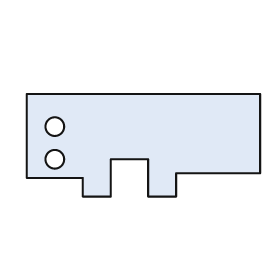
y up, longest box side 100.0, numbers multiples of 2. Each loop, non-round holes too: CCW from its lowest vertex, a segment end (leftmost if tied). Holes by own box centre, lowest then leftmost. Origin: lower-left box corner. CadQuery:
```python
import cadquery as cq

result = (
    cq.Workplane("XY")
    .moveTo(24.0, 0.0)
    .lineTo(36.0, 0.0)
    .lineTo(36.0, 16.0)
    .lineTo(52.0, 16.0)
    .lineTo(52.0, 0.0)
    .lineTo(64.0, 0.0)
    .lineTo(64.0, 10.0)
    .lineTo(100.0, 10.0)
    .lineTo(100.0, 44.0)
    .lineTo(0.0, 44.0)
    .lineTo(0.0, 8.0)
    .lineTo(24.0, 8.0)
    .close()
    .moveTo(12.0, 16.0)
    .circle(4.0)
    .moveTo(12.0, 30.0)
    .circle(4.0)
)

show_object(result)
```